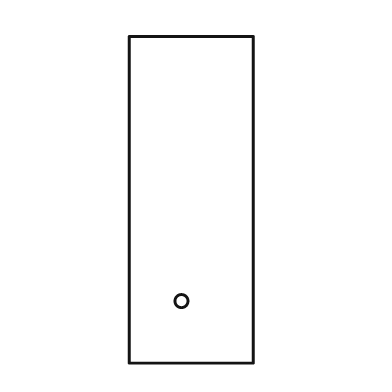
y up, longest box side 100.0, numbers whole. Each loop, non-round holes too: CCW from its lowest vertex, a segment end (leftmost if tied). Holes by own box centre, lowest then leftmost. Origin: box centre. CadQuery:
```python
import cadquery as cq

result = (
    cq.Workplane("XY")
    .moveTo(-19.0, -50.0)
    .lineTo(19.0, -50.0)
    .lineTo(19.0, 50.0)
    .lineTo(-19.0, 50.0)
    .close()
    .moveTo(-3.0, -31.0)
    .circle(2.0)
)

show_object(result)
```